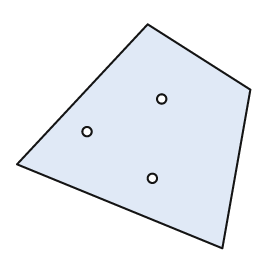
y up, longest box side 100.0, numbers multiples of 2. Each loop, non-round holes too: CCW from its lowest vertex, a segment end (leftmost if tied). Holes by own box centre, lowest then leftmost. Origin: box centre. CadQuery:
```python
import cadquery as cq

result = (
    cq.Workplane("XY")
    .moveTo(38.0, -48.0)
    .lineTo(50.0, 20.0)
    .lineTo(6.0, 48.0)
    .lineTo(-50.0, -12.0)
    .close()
    .moveTo(8.0, -18.0)
    .circle(2.0)
    .moveTo(-20.0, 2.0)
    .circle(2.0)
    .moveTo(12.0, 16.0)
    .circle(2.0)
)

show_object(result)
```